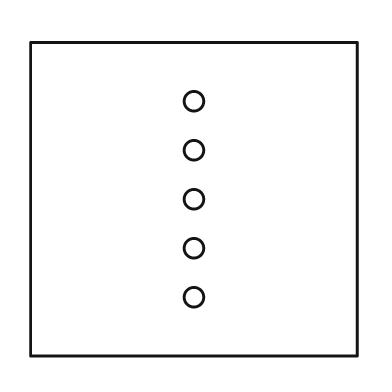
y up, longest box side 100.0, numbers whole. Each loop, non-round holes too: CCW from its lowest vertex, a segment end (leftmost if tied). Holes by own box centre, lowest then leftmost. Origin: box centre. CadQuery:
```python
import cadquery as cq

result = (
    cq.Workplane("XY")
    .moveTo(-50.0, -48.0)
    .lineTo(50.0, -48.0)
    .lineTo(50.0, 48.0)
    .lineTo(-50.0, 48.0)
    .close()
    .moveTo(0.0, -30.0)
    .circle(3.0)
    .moveTo(0.0, -15.0)
    .circle(3.0)
    .moveTo(0.0, 0.0)
    .circle(3.0)
    .moveTo(0.0, 15.0)
    .circle(3.0)
    .moveTo(0.0, 30.0)
    .circle(3.0)
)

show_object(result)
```